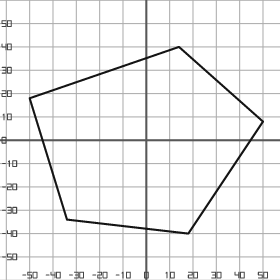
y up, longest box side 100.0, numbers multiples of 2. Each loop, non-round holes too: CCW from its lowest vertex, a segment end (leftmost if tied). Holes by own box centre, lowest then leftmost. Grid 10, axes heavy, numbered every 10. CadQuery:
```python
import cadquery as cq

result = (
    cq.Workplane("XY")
    .moveTo(18.0, -40.0)
    .lineTo(50.0, 8.0)
    .lineTo(14.0, 40.0)
    .lineTo(-50.0, 18.0)
    .lineTo(-34.0, -34.0)
    .close()
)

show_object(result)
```